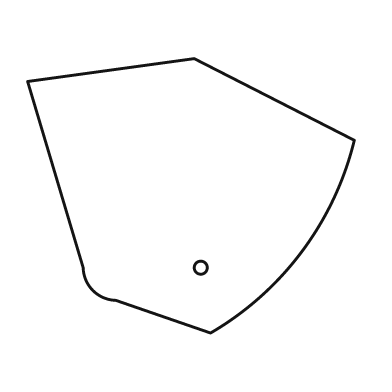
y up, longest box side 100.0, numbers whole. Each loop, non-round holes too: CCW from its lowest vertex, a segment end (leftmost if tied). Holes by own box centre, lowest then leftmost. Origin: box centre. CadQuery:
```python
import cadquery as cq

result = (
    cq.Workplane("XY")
    .moveTo(6.0, -42.0)
    .threePointArc((34.0, -17.0), (50.0, 17.0))
    .lineTo(1.0, 42.0)
    .lineTo(-50.0, 35.0)
    .lineTo(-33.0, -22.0)
    .threePointArc((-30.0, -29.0), (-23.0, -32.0))
    .close()
    .moveTo(3.0, -22.0)
    .circle(2.0)
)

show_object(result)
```